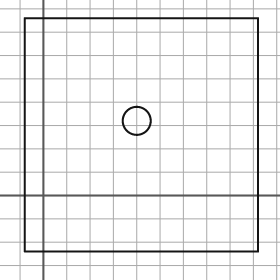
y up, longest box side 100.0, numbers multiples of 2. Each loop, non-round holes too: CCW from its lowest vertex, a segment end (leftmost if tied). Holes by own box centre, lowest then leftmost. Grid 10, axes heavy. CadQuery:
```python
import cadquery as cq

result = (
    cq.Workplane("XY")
    .moveTo(-8.0, -24.0)
    .lineTo(92.0, -24.0)
    .lineTo(92.0, 76.0)
    .lineTo(-8.0, 76.0)
    .close()
    .moveTo(40.0, 32.0)
    .circle(6.0)
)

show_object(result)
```